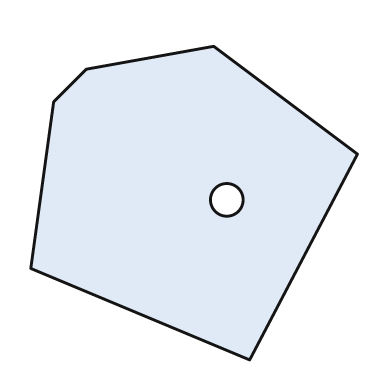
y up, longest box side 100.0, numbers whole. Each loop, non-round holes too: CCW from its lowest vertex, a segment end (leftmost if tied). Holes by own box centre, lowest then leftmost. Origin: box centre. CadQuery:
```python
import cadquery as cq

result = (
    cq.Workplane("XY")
    .moveTo(17.0, -48.0)
    .lineTo(50.0, 15.0)
    .lineTo(6.0, 48.0)
    .lineTo(-33.0, 41.0)
    .lineTo(-43.0, 31.0)
    .lineTo(-50.0, -20.0)
    .close()
    .moveTo(10.0, 1.0)
    .circle(5.0)
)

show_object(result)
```